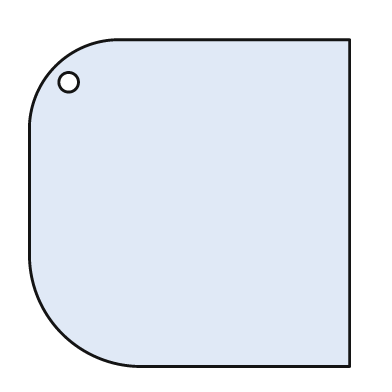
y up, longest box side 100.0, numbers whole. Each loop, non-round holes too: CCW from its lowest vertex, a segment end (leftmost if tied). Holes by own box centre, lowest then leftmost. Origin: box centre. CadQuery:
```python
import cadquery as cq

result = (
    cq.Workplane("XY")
    .moveTo(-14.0, -50.0)
    .lineTo(49.0, -50.0)
    .lineTo(49.0, 50.0)
    .lineTo(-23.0, 50.0)
    .threePointArc((-41.0, 42.0), (-49.0, 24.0))
    .lineTo(-49.0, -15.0)
    .threePointArc((-39.0, -40.0), (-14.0, -50.0))
    .close()
    .moveTo(-37.0, 37.0)
    .circle(3.0)
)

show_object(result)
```